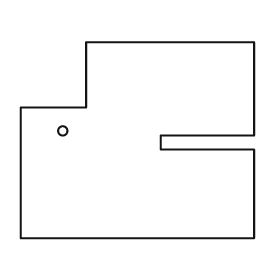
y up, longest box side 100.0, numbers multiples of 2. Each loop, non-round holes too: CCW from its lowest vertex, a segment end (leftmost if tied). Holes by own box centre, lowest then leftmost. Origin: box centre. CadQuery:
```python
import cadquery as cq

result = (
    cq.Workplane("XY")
    .moveTo(-50.0, -42.0)
    .lineTo(50.0, -42.0)
    .lineTo(50.0, -4.0)
    .lineTo(10.0, -4.0)
    .lineTo(10.0, 2.0)
    .lineTo(50.0, 2.0)
    .lineTo(50.0, 42.0)
    .lineTo(-22.0, 42.0)
    .lineTo(-22.0, 14.0)
    .lineTo(-50.0, 14.0)
    .close()
    .moveTo(-32.0, 4.0)
    .circle(2.0)
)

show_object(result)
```